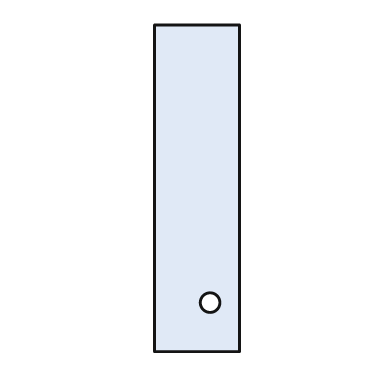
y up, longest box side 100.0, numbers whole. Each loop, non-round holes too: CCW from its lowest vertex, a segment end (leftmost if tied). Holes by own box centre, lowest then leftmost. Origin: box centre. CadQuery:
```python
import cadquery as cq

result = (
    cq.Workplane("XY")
    .moveTo(-13.0, -50.0)
    .lineTo(13.0, -50.0)
    .lineTo(13.0, 50.0)
    .lineTo(-13.0, 50.0)
    .close()
    .moveTo(4.0, -35.0)
    .circle(3.0)
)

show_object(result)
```